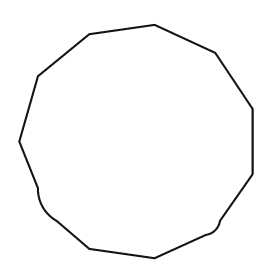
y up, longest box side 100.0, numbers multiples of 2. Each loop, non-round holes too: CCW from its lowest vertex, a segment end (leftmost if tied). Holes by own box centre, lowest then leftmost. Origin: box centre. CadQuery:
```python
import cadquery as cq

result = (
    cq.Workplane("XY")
    .moveTo(8.0, -50.0)
    .lineTo(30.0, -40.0)
    .threePointArc((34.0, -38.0), (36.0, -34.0))
    .lineTo(50.0, -14.0)
    .lineTo(50.0, 14.0)
    .lineTo(34.0, 38.0)
    .lineTo(8.0, 50.0)
    .lineTo(-20.0, 46.0)
    .lineTo(-42.0, 28.0)
    .lineTo(-50.0, 0.0)
    .lineTo(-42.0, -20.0)
    .threePointArc((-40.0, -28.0), (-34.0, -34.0))
    .lineTo(-20.0, -46.0)
    .close()
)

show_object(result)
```